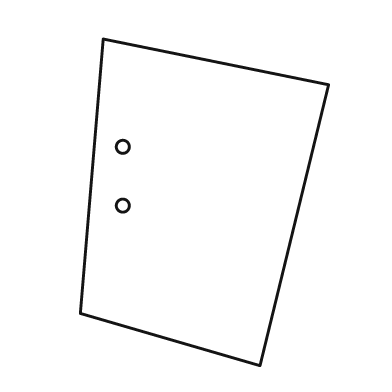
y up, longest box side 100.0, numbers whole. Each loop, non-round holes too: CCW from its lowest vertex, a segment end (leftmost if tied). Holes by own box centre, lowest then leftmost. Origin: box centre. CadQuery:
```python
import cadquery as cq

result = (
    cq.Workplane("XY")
    .moveTo(17.0, -50.0)
    .lineTo(38.0, 36.0)
    .lineTo(-31.0, 50.0)
    .lineTo(-38.0, -34.0)
    .close()
    .moveTo(-25.0, -1.0)
    .circle(2.0)
    .moveTo(-25.0, 17.0)
    .circle(2.0)
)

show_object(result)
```